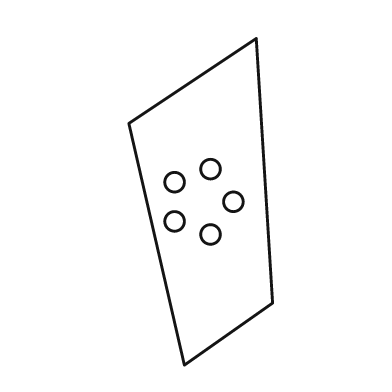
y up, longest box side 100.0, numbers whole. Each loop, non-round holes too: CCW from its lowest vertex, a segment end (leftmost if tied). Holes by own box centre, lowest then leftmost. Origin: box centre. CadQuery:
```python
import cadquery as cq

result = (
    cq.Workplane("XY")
    .moveTo(-5.0, -50.0)
    .lineTo(22.0, -31.0)
    .lineTo(17.0, 50.0)
    .lineTo(-22.0, 24.0)
    .close()
    .moveTo(3.0, -10.0)
    .circle(3.0)
    .moveTo(-8.0, -6.0)
    .circle(3.0)
    .moveTo(10.0, 0.0)
    .circle(3.0)
    .moveTo(-8.0, 6.0)
    .circle(3.0)
    .moveTo(3.0, 10.0)
    .circle(3.0)
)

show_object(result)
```